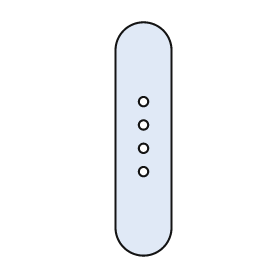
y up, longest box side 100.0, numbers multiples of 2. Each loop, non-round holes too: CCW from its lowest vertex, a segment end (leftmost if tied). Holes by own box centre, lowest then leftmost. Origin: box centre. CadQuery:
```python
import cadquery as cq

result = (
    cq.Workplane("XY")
    .moveTo(-12.0, -38.0)
    .threePointArc((0.0, -50.0), (12.0, -38.0))
    .lineTo(12.0, 38.0)
    .threePointArc((0.0, 50.0), (-12.0, 38.0))
    .close()
    .moveTo(0.0, -14.0)
    .circle(2.0)
    .moveTo(0.0, -4.0)
    .circle(2.0)
    .moveTo(0.0, 6.0)
    .circle(2.0)
    .moveTo(0.0, 16.0)
    .circle(2.0)
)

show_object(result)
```